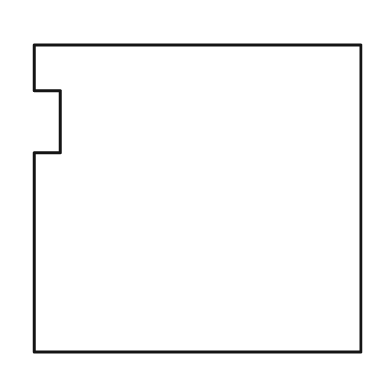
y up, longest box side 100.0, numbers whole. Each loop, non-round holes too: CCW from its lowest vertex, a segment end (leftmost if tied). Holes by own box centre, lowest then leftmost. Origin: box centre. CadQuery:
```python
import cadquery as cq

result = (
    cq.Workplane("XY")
    .moveTo(-50.0, -47.0)
    .lineTo(50.0, -47.0)
    .lineTo(50.0, 47.0)
    .lineTo(-50.0, 47.0)
    .lineTo(-50.0, 33.0)
    .lineTo(-42.0, 33.0)
    .lineTo(-42.0, 14.0)
    .lineTo(-50.0, 14.0)
    .close()
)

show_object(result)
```